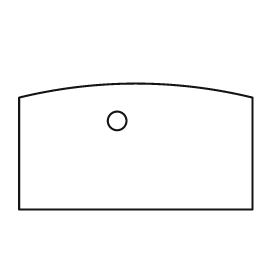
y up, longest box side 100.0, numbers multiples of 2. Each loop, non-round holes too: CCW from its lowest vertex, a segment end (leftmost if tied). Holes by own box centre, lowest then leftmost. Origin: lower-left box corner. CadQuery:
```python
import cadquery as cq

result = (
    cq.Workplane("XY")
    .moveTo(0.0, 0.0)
    .lineTo(100.0, 0.0)
    .lineTo(100.0, 48.0)
    .threePointArc((50.0, 54.0), (0.0, 48.0))
    .close()
    .moveTo(42.0, 38.0)
    .circle(4.0)
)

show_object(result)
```